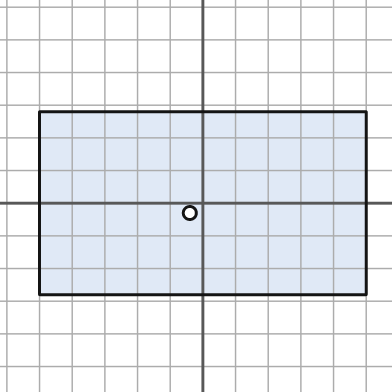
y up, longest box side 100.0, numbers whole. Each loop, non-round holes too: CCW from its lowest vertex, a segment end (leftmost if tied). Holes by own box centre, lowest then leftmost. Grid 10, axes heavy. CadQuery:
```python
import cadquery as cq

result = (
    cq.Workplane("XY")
    .moveTo(-50.0, -28.0)
    .lineTo(50.0, -28.0)
    .lineTo(50.0, 28.0)
    .lineTo(-50.0, 28.0)
    .close()
    .moveTo(-4.0, -3.0)
    .circle(2.0)
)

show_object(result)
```